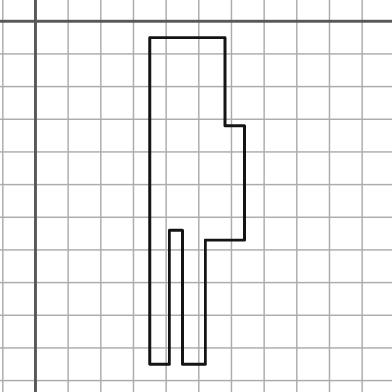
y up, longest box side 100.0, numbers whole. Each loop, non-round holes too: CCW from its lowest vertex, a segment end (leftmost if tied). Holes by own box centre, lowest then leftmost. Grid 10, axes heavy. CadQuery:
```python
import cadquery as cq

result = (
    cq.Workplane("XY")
    .moveTo(35.0, -105.0)
    .lineTo(41.0, -105.0)
    .lineTo(41.0, -64.0)
    .lineTo(45.0, -64.0)
    .lineTo(45.0, -105.0)
    .lineTo(52.0, -105.0)
    .lineTo(52.0, -67.0)
    .lineTo(64.0, -67.0)
    .lineTo(64.0, -32.0)
    .lineTo(58.0, -32.0)
    .lineTo(58.0, -5.0)
    .lineTo(35.0, -5.0)
    .close()
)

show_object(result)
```